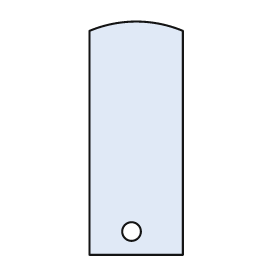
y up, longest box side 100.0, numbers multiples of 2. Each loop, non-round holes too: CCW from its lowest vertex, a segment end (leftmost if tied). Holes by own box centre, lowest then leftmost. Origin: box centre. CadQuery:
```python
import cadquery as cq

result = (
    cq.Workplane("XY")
    .moveTo(-20.0, -50.0)
    .lineTo(20.0, -50.0)
    .lineTo(20.0, 46.0)
    .threePointArc((0.0, 50.0), (-20.0, 46.0))
    .close()
    .moveTo(-2.0, -40.0)
    .circle(4.0)
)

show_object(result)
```